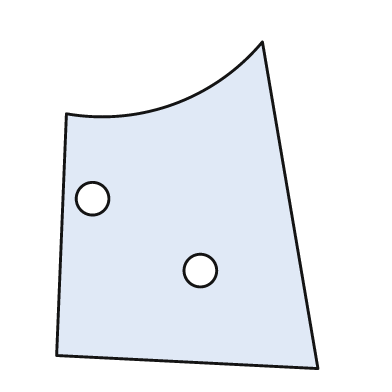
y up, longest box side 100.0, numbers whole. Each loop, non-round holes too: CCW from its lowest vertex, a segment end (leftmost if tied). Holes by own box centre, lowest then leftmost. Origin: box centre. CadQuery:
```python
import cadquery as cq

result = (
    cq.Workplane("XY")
    .moveTo(40.0, -50.0)
    .lineTo(23.0, 50.0)
    .threePointArc((-4.0, 31.0), (-37.0, 28.0))
    .lineTo(-40.0, -46.0)
    .close()
    .moveTo(4.0, -20.0)
    .circle(5.0)
    .moveTo(-29.0, 2.0)
    .circle(5.0)
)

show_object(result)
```